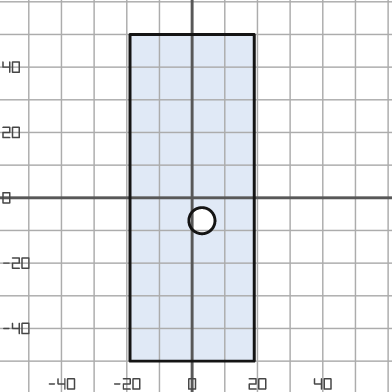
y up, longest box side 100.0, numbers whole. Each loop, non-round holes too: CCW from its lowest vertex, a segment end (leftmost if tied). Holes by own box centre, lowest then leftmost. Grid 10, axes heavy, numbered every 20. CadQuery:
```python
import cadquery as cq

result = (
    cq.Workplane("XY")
    .moveTo(-19.0, -50.0)
    .lineTo(19.0, -50.0)
    .lineTo(19.0, 50.0)
    .lineTo(-19.0, 50.0)
    .close()
    .moveTo(3.0, -7.0)
    .circle(4.0)
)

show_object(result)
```